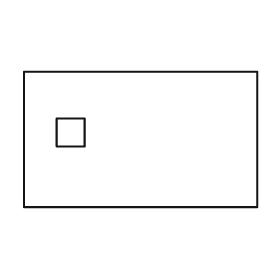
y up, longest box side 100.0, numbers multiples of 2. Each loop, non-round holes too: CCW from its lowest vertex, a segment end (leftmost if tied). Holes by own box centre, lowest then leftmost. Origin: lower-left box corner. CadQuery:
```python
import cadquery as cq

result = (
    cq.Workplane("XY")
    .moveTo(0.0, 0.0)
    .lineTo(100.0, 0.0)
    .lineTo(100.0, 58.0)
    .lineTo(0.0, 58.0)
    .close()
    .moveTo(14.0, 26.0)
    .lineTo(26.0, 26.0)
    .lineTo(26.0, 38.0)
    .lineTo(14.0, 38.0)
    .close()
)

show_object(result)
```